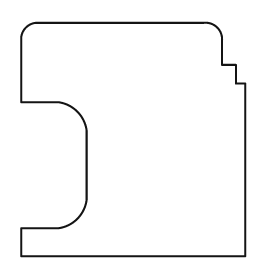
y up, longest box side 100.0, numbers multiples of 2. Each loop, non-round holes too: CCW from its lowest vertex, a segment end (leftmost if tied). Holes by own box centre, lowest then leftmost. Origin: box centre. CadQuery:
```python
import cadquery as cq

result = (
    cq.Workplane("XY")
    .moveTo(-48.0, -50.0)
    .lineTo(48.0, -50.0)
    .lineTo(48.0, 24.0)
    .lineTo(44.0, 24.0)
    .lineTo(44.0, 32.0)
    .lineTo(38.0, 32.0)
    .lineTo(38.0, 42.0)
    .threePointArc((36.0, 48.0), (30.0, 50.0))
    .lineTo(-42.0, 50.0)
    .threePointArc((-46.0, 48.0), (-48.0, 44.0))
    .lineTo(-48.0, 16.0)
    .lineTo(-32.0, 16.0)
    .threePointArc((-24.0, 12.0), (-20.0, 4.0))
    .lineTo(-20.0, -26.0)
    .threePointArc((-24.0, -34.0), (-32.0, -38.0))
    .lineTo(-48.0, -38.0)
    .close()
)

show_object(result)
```